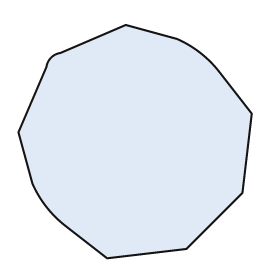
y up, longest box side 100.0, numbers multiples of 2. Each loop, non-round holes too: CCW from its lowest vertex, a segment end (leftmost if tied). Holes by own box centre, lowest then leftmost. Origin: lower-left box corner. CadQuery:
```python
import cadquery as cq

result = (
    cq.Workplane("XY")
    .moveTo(38.0, 0.0)
    .lineTo(72.0, 4.0)
    .lineTo(96.0, 28.0)
    .lineTo(100.0, 62.0)
    .lineTo(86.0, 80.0)
    .threePointArc((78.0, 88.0), (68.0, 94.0))
    .lineTo(46.0, 100.0)
    .lineTo(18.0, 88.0)
    .threePointArc((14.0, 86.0), (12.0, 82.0))
    .lineTo(0.0, 54.0)
    .lineTo(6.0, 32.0)
    .threePointArc((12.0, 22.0), (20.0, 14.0))
    .close()
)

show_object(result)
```